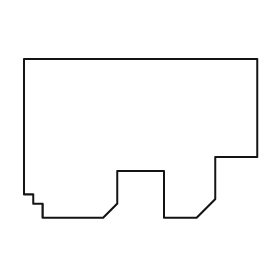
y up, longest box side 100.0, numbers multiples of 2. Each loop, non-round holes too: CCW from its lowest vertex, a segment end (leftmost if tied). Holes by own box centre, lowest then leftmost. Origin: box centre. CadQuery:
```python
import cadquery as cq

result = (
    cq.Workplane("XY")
    .moveTo(-42.0, -34.0)
    .lineTo(-16.0, -34.0)
    .lineTo(-10.0, -28.0)
    .lineTo(-10.0, -14.0)
    .lineTo(10.0, -14.0)
    .lineTo(10.0, -34.0)
    .lineTo(24.0, -34.0)
    .lineTo(32.0, -26.0)
    .lineTo(32.0, -8.0)
    .lineTo(50.0, -8.0)
    .lineTo(50.0, 34.0)
    .lineTo(-50.0, 34.0)
    .lineTo(-50.0, -24.0)
    .lineTo(-46.0, -24.0)
    .lineTo(-46.0, -28.0)
    .lineTo(-42.0, -28.0)
    .close()
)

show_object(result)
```